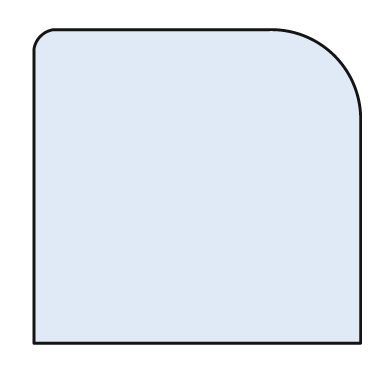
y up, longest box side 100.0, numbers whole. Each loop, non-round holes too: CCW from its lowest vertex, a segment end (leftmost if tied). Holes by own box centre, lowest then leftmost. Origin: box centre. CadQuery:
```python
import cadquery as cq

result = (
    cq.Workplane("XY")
    .moveTo(-50.0, -48.0)
    .lineTo(50.0, -48.0)
    .lineTo(50.0, 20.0)
    .threePointArc((42.0, 40.0), (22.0, 48.0))
    .lineTo(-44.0, 48.0)
    .threePointArc((-48.0, 46.0), (-50.0, 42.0))
    .close()
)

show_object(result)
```